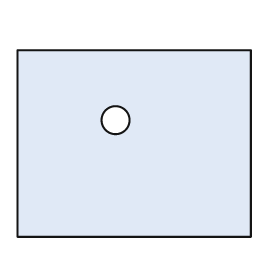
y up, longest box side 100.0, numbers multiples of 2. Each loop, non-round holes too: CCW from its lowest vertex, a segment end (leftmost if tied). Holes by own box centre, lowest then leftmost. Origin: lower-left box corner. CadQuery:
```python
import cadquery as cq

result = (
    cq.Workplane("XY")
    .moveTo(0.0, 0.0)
    .lineTo(100.0, 0.0)
    .lineTo(100.0, 80.0)
    .lineTo(0.0, 80.0)
    .close()
    .moveTo(42.0, 50.0)
    .circle(6.0)
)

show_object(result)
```